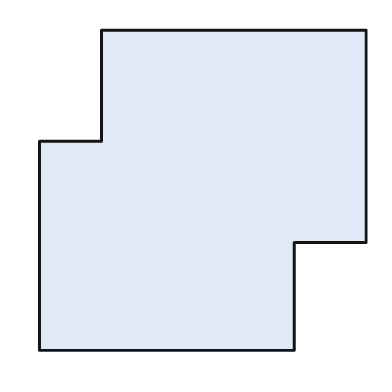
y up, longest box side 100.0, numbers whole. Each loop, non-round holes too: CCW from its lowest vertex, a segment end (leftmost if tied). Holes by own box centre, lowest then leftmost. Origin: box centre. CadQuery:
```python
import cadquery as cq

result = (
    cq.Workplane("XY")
    .moveTo(-50.0, -49.0)
    .lineTo(28.0, -49.0)
    .lineTo(28.0, -16.0)
    .lineTo(50.0, -16.0)
    .lineTo(50.0, 49.0)
    .lineTo(-31.0, 49.0)
    .lineTo(-31.0, 15.0)
    .lineTo(-50.0, 15.0)
    .close()
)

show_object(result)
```